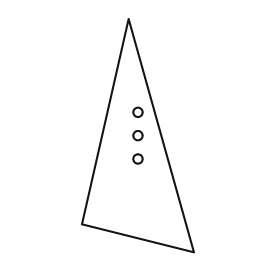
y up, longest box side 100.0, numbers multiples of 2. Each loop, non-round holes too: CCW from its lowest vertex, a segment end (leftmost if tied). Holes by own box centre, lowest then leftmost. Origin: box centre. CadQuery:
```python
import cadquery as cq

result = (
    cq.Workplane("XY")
    .moveTo(24.0, -50.0)
    .lineTo(-4.0, 50.0)
    .lineTo(-24.0, -38.0)
    .close()
    .moveTo(0.0, -10.0)
    .circle(2.0)
    .moveTo(0.0, 0.0)
    .circle(2.0)
    .moveTo(0.0, 10.0)
    .circle(2.0)
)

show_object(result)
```